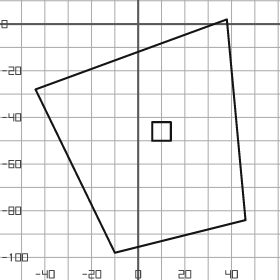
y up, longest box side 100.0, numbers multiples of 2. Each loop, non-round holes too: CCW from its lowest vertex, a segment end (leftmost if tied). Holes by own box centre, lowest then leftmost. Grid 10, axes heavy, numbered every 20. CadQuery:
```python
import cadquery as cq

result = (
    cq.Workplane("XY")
    .moveTo(-10.0, -98.0)
    .lineTo(46.0, -84.0)
    .lineTo(38.0, 2.0)
    .lineTo(-44.0, -28.0)
    .close()
    .moveTo(6.0, -50.0)
    .lineTo(14.0, -50.0)
    .lineTo(14.0, -42.0)
    .lineTo(6.0, -42.0)
    .close()
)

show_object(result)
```